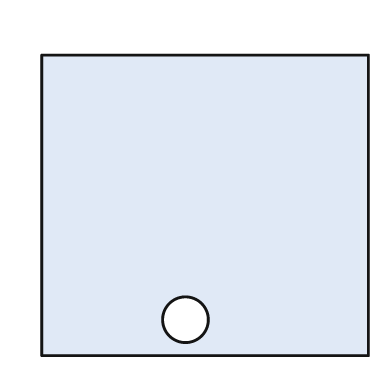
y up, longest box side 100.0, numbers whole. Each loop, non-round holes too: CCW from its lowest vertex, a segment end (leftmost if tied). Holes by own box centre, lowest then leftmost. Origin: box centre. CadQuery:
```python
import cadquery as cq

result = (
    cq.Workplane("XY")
    .moveTo(-50.0, -46.0)
    .lineTo(50.0, -46.0)
    .lineTo(50.0, 46.0)
    .lineTo(-50.0, 46.0)
    .close()
    .moveTo(-6.0, -35.0)
    .circle(7.0)
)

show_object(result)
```